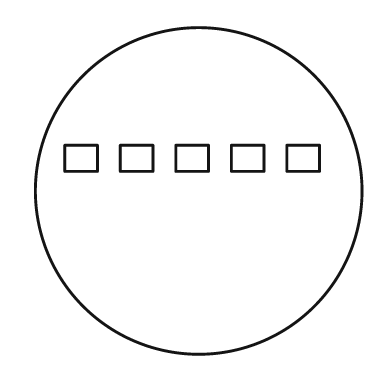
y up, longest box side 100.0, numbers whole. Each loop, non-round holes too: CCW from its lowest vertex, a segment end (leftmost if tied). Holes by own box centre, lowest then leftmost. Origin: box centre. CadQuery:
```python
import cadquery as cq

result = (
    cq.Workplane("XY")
    .moveTo(0.0, 0.0)
    .circle(50.0)
    .moveTo(-41.0, 6.0)
    .lineTo(-31.0, 6.0)
    .lineTo(-31.0, 14.0)
    .lineTo(-41.0, 14.0)
    .close()
    .moveTo(-24.0, 6.0)
    .lineTo(-14.0, 6.0)
    .lineTo(-14.0, 14.0)
    .lineTo(-24.0, 14.0)
    .close()
    .moveTo(-7.0, 6.0)
    .lineTo(3.0, 6.0)
    .lineTo(3.0, 14.0)
    .lineTo(-7.0, 14.0)
    .close()
    .moveTo(10.0, 6.0)
    .lineTo(20.0, 6.0)
    .lineTo(20.0, 14.0)
    .lineTo(10.0, 14.0)
    .close()
    .moveTo(27.0, 6.0)
    .lineTo(37.0, 6.0)
    .lineTo(37.0, 14.0)
    .lineTo(27.0, 14.0)
    .close()
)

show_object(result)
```